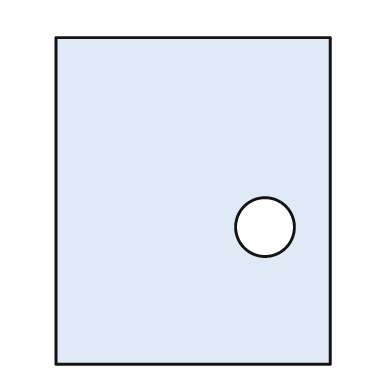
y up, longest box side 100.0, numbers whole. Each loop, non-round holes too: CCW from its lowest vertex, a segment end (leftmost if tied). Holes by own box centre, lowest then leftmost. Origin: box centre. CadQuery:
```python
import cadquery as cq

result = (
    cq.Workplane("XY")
    .moveTo(-42.0, -50.0)
    .lineTo(42.0, -50.0)
    .lineTo(42.0, 50.0)
    .lineTo(-42.0, 50.0)
    .close()
    .moveTo(22.0, -8.0)
    .circle(9.0)
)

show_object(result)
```